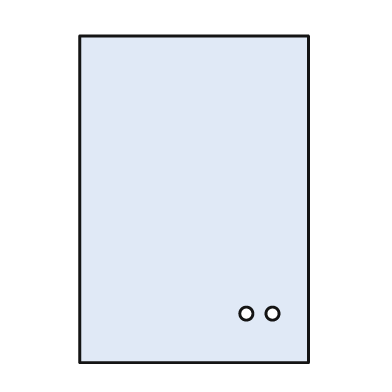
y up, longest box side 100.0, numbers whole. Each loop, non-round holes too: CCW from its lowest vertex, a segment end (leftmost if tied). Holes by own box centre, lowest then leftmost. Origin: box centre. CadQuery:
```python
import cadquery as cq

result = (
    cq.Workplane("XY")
    .moveTo(-35.0, -50.0)
    .lineTo(35.0, -50.0)
    .lineTo(35.0, 50.0)
    .lineTo(-35.0, 50.0)
    .close()
    .moveTo(16.0, -35.0)
    .circle(2.0)
    .moveTo(24.0, -35.0)
    .circle(2.0)
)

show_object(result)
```